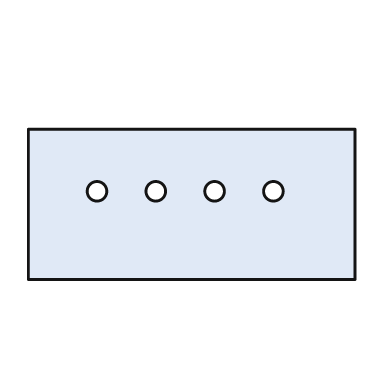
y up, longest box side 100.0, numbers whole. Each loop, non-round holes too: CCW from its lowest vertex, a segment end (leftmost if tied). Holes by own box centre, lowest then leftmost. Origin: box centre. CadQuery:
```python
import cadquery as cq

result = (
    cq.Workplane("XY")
    .moveTo(-50.0, -23.0)
    .lineTo(50.0, -23.0)
    .lineTo(50.0, 23.0)
    .lineTo(-50.0, 23.0)
    .close()
    .moveTo(-29.0, 4.0)
    .circle(3.0)
    .moveTo(-11.0, 4.0)
    .circle(3.0)
    .moveTo(7.0, 4.0)
    .circle(3.0)
    .moveTo(25.0, 4.0)
    .circle(3.0)
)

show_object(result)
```